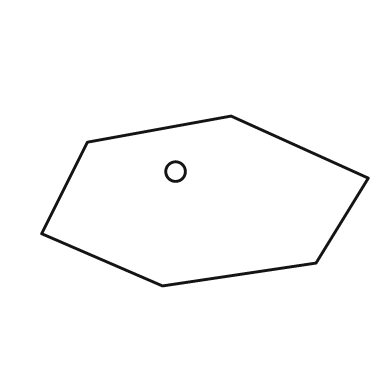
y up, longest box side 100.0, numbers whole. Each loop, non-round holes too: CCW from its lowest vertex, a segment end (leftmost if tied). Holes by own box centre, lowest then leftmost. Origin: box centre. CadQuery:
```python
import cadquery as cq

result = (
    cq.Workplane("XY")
    .moveTo(-13.0, -26.0)
    .lineTo(34.0, -19.0)
    .lineTo(50.0, 7.0)
    .lineTo(8.0, 26.0)
    .lineTo(-36.0, 18.0)
    .lineTo(-50.0, -10.0)
    .close()
    .moveTo(-9.0, 9.0)
    .circle(3.0)
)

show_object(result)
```